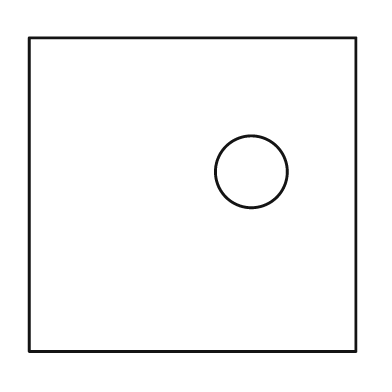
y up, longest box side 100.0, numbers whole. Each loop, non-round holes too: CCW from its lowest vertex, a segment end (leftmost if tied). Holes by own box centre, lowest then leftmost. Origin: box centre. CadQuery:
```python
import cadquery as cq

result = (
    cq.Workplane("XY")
    .moveTo(-50.0, -48.0)
    .lineTo(50.0, -48.0)
    .lineTo(50.0, 48.0)
    .lineTo(-50.0, 48.0)
    .close()
    .moveTo(18.0, 7.0)
    .circle(11.0)
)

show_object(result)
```